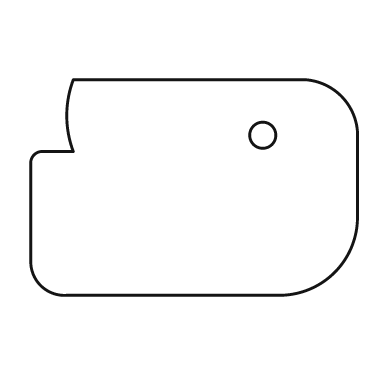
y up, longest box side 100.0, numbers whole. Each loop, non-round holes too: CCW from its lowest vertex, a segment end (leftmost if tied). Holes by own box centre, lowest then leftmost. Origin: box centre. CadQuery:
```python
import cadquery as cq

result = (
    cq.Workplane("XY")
    .moveTo(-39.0, -33.0)
    .lineTo(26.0, -33.0)
    .threePointArc((43.0, -26.0), (50.0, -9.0))
    .lineTo(50.0, 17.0)
    .threePointArc((45.0, 28.0), (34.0, 33.0))
    .lineTo(-37.0, 33.0)
    .threePointArc((-39.0, 22.0), (-37.0, 11.0))
    .lineTo(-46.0, 11.0)
    .threePointArc((-49.0, 10.0), (-50.0, 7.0))
    .lineTo(-50.0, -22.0)
    .threePointArc((-47.0, -30.0), (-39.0, -33.0))
    .close()
    .moveTo(21.0, 16.0)
    .circle(4.0)
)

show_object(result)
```